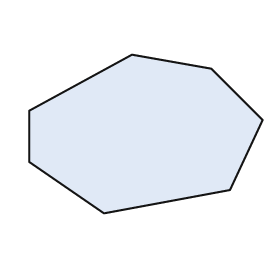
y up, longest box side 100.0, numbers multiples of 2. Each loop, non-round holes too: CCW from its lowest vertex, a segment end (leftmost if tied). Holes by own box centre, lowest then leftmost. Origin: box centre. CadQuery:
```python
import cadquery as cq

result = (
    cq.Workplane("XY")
    .moveTo(-18.0, -34.0)
    .lineTo(36.0, -24.0)
    .lineTo(50.0, 6.0)
    .lineTo(28.0, 28.0)
    .lineTo(-6.0, 34.0)
    .lineTo(-50.0, 10.0)
    .lineTo(-50.0, -12.0)
    .close()
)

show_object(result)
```